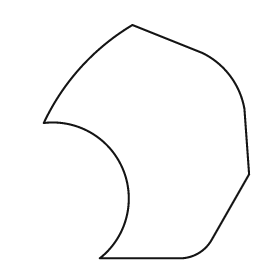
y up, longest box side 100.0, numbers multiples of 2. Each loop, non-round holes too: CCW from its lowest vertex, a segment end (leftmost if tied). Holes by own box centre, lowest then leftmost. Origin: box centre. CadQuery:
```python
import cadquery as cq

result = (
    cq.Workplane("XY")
    .moveTo(-20.0, -50.0)
    .lineTo(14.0, -50.0)
    .threePointArc((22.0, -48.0), (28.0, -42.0))
    .lineTo(44.0, -14.0)
    .lineTo(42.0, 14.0)
    .threePointArc((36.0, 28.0), (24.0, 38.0))
    .lineTo(-6.0, 50.0)
    .threePointArc((-28.0, 32.0), (-44.0, 8.0))
    .threePointArc((-10.0, -12.0), (-20.0, -50.0))
    .close()
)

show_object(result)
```